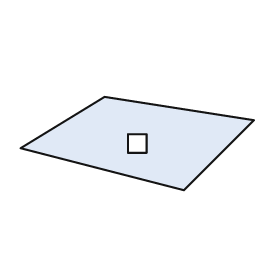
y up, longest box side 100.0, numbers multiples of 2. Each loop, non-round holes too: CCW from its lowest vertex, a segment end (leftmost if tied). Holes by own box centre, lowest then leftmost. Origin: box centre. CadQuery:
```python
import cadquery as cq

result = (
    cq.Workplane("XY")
    .moveTo(20.0, -20.0)
    .lineTo(50.0, 10.0)
    .lineTo(-14.0, 20.0)
    .lineTo(-50.0, -2.0)
    .close()
    .moveTo(-4.0, -4.0)
    .lineTo(4.0, -4.0)
    .lineTo(4.0, 4.0)
    .lineTo(-4.0, 4.0)
    .close()
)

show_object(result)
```